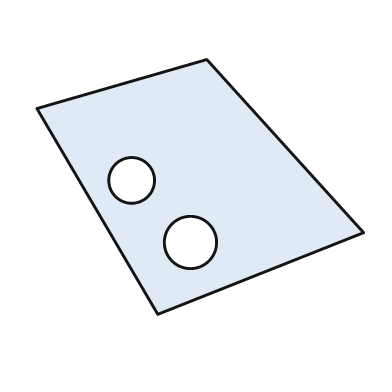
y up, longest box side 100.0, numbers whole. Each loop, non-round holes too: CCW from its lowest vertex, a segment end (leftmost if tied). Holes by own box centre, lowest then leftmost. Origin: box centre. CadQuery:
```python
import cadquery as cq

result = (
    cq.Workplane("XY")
    .moveTo(-13.0, -39.0)
    .lineTo(50.0, -14.0)
    .lineTo(2.0, 39.0)
    .lineTo(-50.0, 24.0)
    .close()
    .moveTo(-3.0, -17.0)
    .circle(8.0)
    .moveTo(-21.0, 2.0)
    .circle(7.0)
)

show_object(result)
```